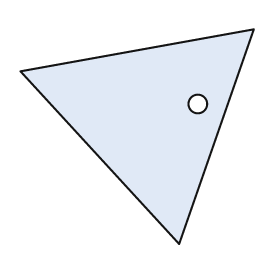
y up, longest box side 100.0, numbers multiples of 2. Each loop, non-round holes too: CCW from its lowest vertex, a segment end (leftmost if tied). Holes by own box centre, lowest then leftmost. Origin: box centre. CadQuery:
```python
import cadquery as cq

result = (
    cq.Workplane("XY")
    .moveTo(18.0, -46.0)
    .lineTo(50.0, 46.0)
    .lineTo(-50.0, 28.0)
    .close()
    .moveTo(26.0, 14.0)
    .circle(4.0)
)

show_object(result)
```